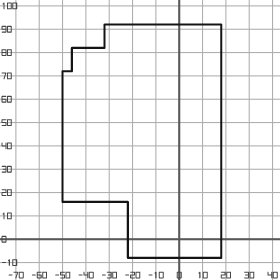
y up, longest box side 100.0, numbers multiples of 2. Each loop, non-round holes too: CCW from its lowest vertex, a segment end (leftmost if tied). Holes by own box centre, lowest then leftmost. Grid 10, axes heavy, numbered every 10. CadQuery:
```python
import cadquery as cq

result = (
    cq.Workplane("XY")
    .moveTo(-22.0, -8.0)
    .lineTo(18.0, -8.0)
    .lineTo(18.0, 92.0)
    .lineTo(-32.0, 92.0)
    .lineTo(-32.0, 82.0)
    .lineTo(-46.0, 82.0)
    .lineTo(-46.0, 72.0)
    .lineTo(-50.0, 72.0)
    .lineTo(-50.0, 16.0)
    .lineTo(-22.0, 16.0)
    .close()
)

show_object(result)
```